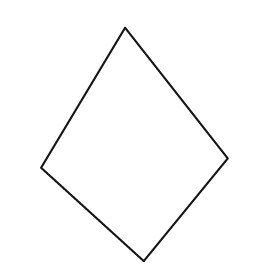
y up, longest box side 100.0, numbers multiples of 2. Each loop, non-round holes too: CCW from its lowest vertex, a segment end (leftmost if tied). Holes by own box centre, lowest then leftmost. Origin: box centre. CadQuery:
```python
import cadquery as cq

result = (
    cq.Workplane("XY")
    .moveTo(4.0, -50.0)
    .lineTo(40.0, -6.0)
    .lineTo(-4.0, 50.0)
    .lineTo(-40.0, -10.0)
    .close()
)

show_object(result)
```